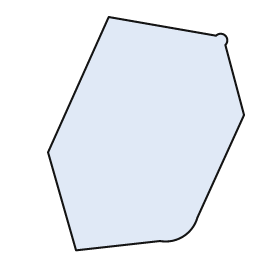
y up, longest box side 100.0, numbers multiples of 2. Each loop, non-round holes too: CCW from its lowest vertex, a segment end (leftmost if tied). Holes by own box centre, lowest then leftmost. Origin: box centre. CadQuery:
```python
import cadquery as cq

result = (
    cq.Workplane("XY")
    .moveTo(-30.0, -50.0)
    .lineTo(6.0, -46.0)
    .threePointArc((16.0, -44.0), (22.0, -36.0))
    .lineTo(42.0, 8.0)
    .lineTo(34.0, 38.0)
    .threePointArc((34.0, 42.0), (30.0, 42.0))
    .lineTo(-16.0, 50.0)
    .lineTo(-42.0, -8.0)
    .close()
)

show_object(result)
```